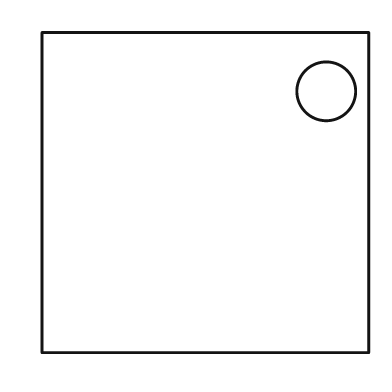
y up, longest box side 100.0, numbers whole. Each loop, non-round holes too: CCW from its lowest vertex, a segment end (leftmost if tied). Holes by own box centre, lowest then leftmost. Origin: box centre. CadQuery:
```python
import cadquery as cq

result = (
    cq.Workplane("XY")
    .moveTo(-50.0, -49.0)
    .lineTo(50.0, -49.0)
    .lineTo(50.0, 49.0)
    .lineTo(-50.0, 49.0)
    .close()
    .moveTo(37.0, 31.0)
    .circle(9.0)
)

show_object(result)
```